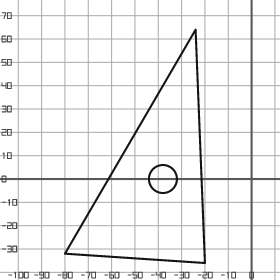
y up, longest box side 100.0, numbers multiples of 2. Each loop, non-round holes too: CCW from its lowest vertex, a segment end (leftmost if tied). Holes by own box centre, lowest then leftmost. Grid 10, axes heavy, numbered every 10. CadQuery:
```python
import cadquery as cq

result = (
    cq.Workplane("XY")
    .moveTo(-20.0, -36.0)
    .lineTo(-24.0, 64.0)
    .lineTo(-80.0, -32.0)
    .close()
    .moveTo(-38.0, 0.0)
    .circle(6.0)
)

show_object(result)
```